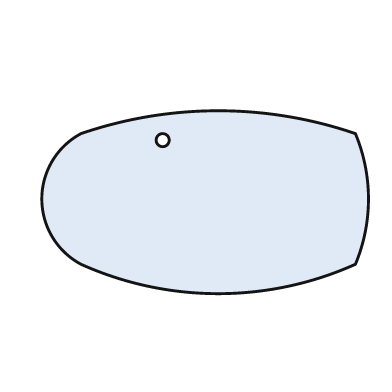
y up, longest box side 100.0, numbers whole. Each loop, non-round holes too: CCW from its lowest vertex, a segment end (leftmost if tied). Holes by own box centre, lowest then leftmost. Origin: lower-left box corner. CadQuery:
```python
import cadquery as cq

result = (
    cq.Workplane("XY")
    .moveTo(12.0, 9.0)
    .threePointArc((54.0, 0.0), (96.0, 9.0))
    .threePointArc((100.0, 29.0), (96.0, 49.0))
    .threePointArc((54.0, 56.0), (12.0, 49.0))
    .threePointArc((0.0, 29.0), (12.0, 9.0))
    .close()
    .moveTo(37.0, 47.0)
    .circle(2.0)
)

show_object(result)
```